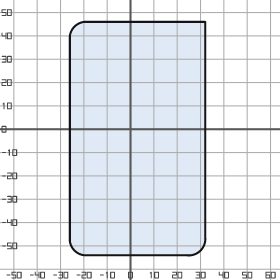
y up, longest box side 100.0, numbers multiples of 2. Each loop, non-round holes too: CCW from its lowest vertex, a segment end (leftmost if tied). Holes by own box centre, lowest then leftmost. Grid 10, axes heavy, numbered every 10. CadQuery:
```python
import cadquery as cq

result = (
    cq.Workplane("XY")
    .moveTo(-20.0, -54.0)
    .lineTo(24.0, -54.0)
    .threePointArc((30.0, -52.0), (32.0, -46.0))
    .lineTo(32.0, 46.0)
    .lineTo(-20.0, 46.0)
    .threePointArc((-24.0, 44.0), (-26.0, 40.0))
    .lineTo(-26.0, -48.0)
    .threePointArc((-24.0, -52.0), (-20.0, -54.0))
    .close()
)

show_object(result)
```